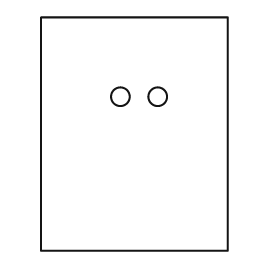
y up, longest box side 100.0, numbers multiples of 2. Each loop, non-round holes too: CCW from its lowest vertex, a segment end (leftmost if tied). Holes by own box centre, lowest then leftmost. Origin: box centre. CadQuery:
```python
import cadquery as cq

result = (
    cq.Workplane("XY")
    .moveTo(-40.0, -50.0)
    .lineTo(40.0, -50.0)
    .lineTo(40.0, 50.0)
    .lineTo(-40.0, 50.0)
    .close()
    .moveTo(-6.0, 16.0)
    .circle(4.0)
    .moveTo(10.0, 16.0)
    .circle(4.0)
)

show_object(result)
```